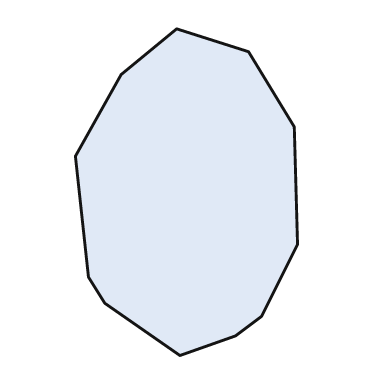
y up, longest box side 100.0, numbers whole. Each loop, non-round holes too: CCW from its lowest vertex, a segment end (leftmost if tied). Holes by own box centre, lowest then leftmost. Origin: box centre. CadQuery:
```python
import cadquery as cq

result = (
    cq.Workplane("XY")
    .moveTo(-2.0, -50.0)
    .lineTo(15.0, -44.0)
    .lineTo(23.0, -38.0)
    .lineTo(34.0, -16.0)
    .lineTo(33.0, 20.0)
    .lineTo(19.0, 43.0)
    .lineTo(-3.0, 50.0)
    .lineTo(-20.0, 36.0)
    .lineTo(-34.0, 11.0)
    .lineTo(-30.0, -26.0)
    .lineTo(-25.0, -34.0)
    .close()
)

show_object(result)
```